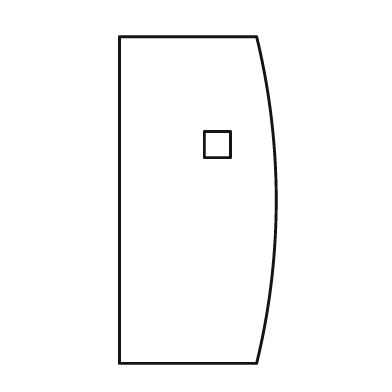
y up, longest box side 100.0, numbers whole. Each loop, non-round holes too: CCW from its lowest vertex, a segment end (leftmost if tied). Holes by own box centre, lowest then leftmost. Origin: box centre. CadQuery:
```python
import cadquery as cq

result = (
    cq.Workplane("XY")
    .moveTo(-24.0, -50.0)
    .lineTo(18.0, -50.0)
    .threePointArc((24.0, 0.0), (18.0, 50.0))
    .lineTo(-24.0, 50.0)
    .close()
    .moveTo(2.0, 13.0)
    .lineTo(10.0, 13.0)
    .lineTo(10.0, 21.0)
    .lineTo(2.0, 21.0)
    .close()
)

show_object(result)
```